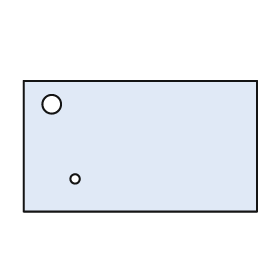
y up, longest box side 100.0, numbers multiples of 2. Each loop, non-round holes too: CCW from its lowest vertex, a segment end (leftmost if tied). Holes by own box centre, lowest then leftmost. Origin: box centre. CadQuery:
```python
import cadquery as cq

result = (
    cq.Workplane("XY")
    .moveTo(-50.0, -28.0)
    .lineTo(50.0, -28.0)
    .lineTo(50.0, 28.0)
    .lineTo(-50.0, 28.0)
    .close()
    .moveTo(-28.0, -14.0)
    .circle(2.0)
    .moveTo(-38.0, 18.0)
    .circle(4.0)
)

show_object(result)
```